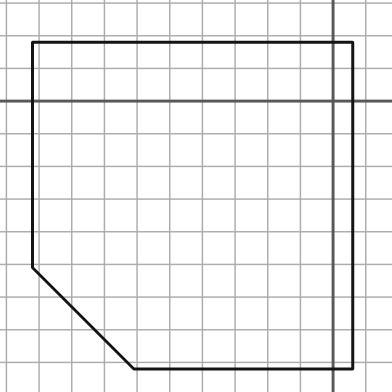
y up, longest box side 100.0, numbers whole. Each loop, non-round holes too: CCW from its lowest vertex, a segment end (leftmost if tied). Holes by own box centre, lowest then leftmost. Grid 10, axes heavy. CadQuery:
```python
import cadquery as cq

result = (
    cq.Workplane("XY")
    .moveTo(-61.0, -82.0)
    .lineTo(6.0, -82.0)
    .lineTo(6.0, 18.0)
    .lineTo(-92.0, 18.0)
    .lineTo(-92.0, -51.0)
    .close()
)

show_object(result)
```